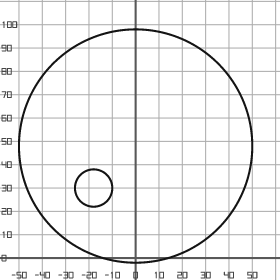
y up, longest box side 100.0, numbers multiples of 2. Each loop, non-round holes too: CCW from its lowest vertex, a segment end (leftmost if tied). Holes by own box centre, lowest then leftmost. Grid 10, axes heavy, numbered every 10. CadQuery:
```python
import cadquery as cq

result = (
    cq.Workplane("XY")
    .moveTo(0.0, 48.0)
    .circle(50.0)
    .moveTo(-18.0, 30.0)
    .circle(8.0)
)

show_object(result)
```